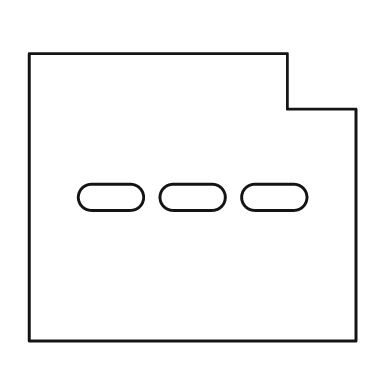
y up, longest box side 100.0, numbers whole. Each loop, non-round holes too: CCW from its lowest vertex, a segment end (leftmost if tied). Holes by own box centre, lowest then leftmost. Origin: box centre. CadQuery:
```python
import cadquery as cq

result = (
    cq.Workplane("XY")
    .moveTo(-50.0, -44.0)
    .lineTo(50.0, -44.0)
    .lineTo(50.0, 27.0)
    .lineTo(29.0, 27.0)
    .lineTo(29.0, 44.0)
    .lineTo(-50.0, 44.0)
    .close()
    .moveTo(-31.0, -4.0)
    .lineTo(-19.0, -4.0)
    .threePointArc((-15.0, 0.0), (-19.0, 4.0))
    .lineTo(-31.0, 4.0)
    .threePointArc((-35.0, 0.0), (-31.0, -4.0))
    .close()
    .moveTo(-6.0, -4.0)
    .lineTo(6.0, -4.0)
    .threePointArc((10.0, 0.0), (6.0, 4.0))
    .lineTo(-6.0, 4.0)
    .threePointArc((-10.0, 0.0), (-6.0, -4.0))
    .close()
    .moveTo(19.0, -4.0)
    .lineTo(31.0, -4.0)
    .threePointArc((35.0, 0.0), (31.0, 4.0))
    .lineTo(19.0, 4.0)
    .threePointArc((15.0, 0.0), (19.0, -4.0))
    .close()
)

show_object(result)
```